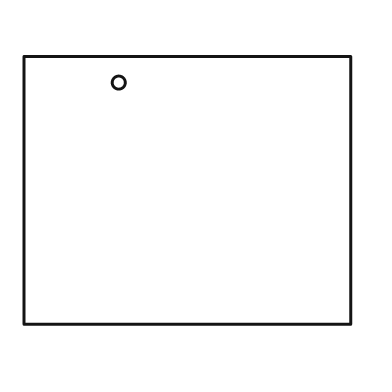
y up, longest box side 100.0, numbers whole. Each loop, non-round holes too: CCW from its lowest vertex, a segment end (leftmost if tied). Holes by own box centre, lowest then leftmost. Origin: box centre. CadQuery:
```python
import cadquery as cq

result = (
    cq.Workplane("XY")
    .moveTo(-50.0, -41.0)
    .lineTo(50.0, -41.0)
    .lineTo(50.0, 41.0)
    .lineTo(-50.0, 41.0)
    .close()
    .moveTo(-21.0, 33.0)
    .circle(2.0)
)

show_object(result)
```